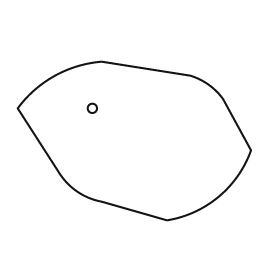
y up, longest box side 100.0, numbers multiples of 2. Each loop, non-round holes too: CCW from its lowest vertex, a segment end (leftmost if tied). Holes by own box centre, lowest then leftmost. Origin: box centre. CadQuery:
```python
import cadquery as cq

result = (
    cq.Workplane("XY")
    .moveTo(14.0, -34.0)
    .threePointArc((36.0, -24.0), (50.0, -4.0))
    .lineTo(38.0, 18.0)
    .threePointArc((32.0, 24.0), (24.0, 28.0))
    .lineTo(-14.0, 34.0)
    .threePointArc((-34.0, 28.0), (-50.0, 14.0))
    .lineTo(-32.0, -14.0)
    .threePointArc((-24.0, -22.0), (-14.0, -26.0))
    .close()
    .moveTo(-18.0, 14.0)
    .circle(2.0)
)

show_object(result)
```